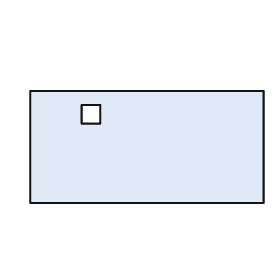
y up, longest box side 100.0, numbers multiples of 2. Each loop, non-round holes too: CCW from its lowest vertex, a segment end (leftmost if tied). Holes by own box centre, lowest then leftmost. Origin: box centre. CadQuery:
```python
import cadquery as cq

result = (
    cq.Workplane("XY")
    .moveTo(-50.0, -24.0)
    .lineTo(50.0, -24.0)
    .lineTo(50.0, 24.0)
    .lineTo(-50.0, 24.0)
    .close()
    .moveTo(-28.0, 10.0)
    .lineTo(-20.0, 10.0)
    .lineTo(-20.0, 18.0)
    .lineTo(-28.0, 18.0)
    .close()
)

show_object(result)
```